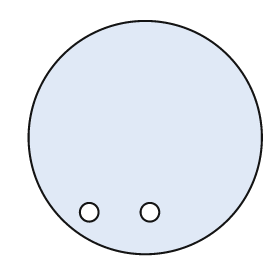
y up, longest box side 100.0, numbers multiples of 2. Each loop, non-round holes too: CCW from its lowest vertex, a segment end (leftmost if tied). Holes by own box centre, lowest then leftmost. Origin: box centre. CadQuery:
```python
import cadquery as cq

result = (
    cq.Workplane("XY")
    .moveTo(0.0, 0.0)
    .circle(50.0)
    .moveTo(-24.0, -32.0)
    .circle(4.0)
    .moveTo(2.0, -32.0)
    .circle(4.0)
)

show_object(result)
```